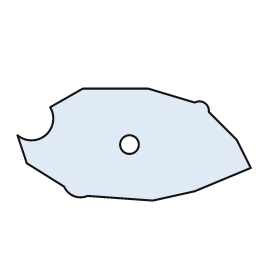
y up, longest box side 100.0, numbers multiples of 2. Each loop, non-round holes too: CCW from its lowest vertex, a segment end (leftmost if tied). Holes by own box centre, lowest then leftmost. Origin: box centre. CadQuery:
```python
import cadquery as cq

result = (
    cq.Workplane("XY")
    .moveTo(8.0, -24.0)
    .lineTo(26.0, -20.0)
    .lineTo(50.0, -10.0)
    .lineTo(44.0, 2.0)
    .lineTo(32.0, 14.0)
    .threePointArc((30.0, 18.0), (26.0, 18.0))
    .lineTo(6.0, 24.0)
    .lineTo(-22.0, 24.0)
    .lineTo(-36.0, 16.0)
    .threePointArc((-38.0, 4.0), (-50.0, 4.0))
    .lineTo(-46.0, -8.0)
    .lineTo(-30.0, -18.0)
    .threePointArc((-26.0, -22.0), (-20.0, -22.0))
    .close()
    .moveTo(-2.0, 0.0)
    .circle(4.0)
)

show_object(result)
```